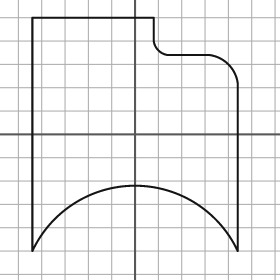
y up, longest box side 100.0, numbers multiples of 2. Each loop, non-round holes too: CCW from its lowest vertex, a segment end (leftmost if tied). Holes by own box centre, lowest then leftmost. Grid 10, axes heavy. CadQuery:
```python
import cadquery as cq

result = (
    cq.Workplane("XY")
    .moveTo(-44.0, -50.0)
    .threePointArc((0.0, -22.0), (44.0, -50.0))
    .lineTo(44.0, 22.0)
    .threePointArc((40.0, 30.0), (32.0, 34.0))
    .lineTo(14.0, 34.0)
    .threePointArc((10.0, 36.0), (8.0, 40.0))
    .lineTo(8.0, 50.0)
    .lineTo(-44.0, 50.0)
    .close()
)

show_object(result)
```